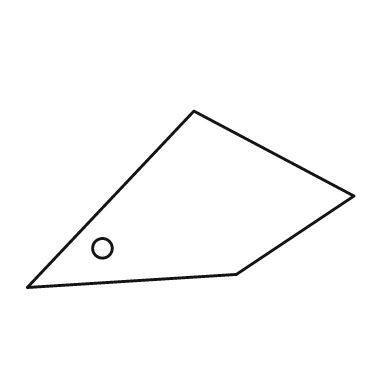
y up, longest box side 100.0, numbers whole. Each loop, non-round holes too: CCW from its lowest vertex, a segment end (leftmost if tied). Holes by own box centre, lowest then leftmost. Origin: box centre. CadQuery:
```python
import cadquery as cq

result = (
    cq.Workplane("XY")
    .moveTo(-50.0, -27.0)
    .lineTo(14.0, -23.0)
    .lineTo(50.0, 1.0)
    .lineTo(1.0, 27.0)
    .close()
    .moveTo(-27.0, -15.0)
    .circle(3.0)
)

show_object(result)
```